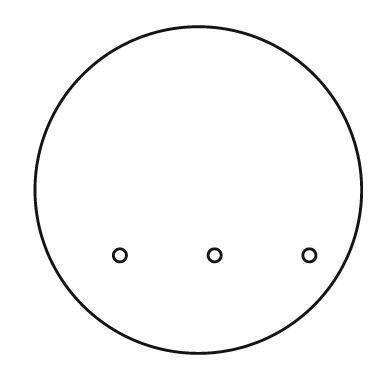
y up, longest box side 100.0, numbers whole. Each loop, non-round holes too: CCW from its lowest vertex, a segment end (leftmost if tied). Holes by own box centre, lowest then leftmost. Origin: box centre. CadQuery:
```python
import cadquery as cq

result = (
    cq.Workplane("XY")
    .moveTo(0.0, 0.0)
    .circle(50.0)
    .moveTo(-24.0, -20.0)
    .circle(2.0)
    .moveTo(5.0, -20.0)
    .circle(2.0)
    .moveTo(34.0, -20.0)
    .circle(2.0)
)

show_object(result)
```